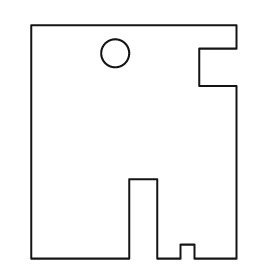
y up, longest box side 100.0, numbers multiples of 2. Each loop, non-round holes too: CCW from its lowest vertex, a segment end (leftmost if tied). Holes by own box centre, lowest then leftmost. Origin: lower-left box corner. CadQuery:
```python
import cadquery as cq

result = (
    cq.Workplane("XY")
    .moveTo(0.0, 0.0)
    .lineTo(42.0, 0.0)
    .lineTo(42.0, 34.0)
    .lineTo(54.0, 34.0)
    .lineTo(54.0, 0.0)
    .lineTo(64.0, 0.0)
    .lineTo(64.0, 6.0)
    .lineTo(70.0, 6.0)
    .lineTo(70.0, 0.0)
    .lineTo(88.0, 0.0)
    .lineTo(88.0, 74.0)
    .lineTo(72.0, 74.0)
    .lineTo(72.0, 90.0)
    .lineTo(88.0, 90.0)
    .lineTo(88.0, 100.0)
    .lineTo(0.0, 100.0)
    .close()
    .moveTo(36.0, 88.0)
    .circle(6.0)
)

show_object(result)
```